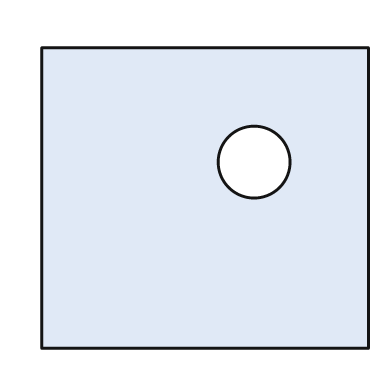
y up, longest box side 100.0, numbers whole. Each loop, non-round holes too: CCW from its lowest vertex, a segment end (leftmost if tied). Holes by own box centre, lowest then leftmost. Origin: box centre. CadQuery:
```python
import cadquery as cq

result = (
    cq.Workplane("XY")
    .moveTo(-50.0, -46.0)
    .lineTo(50.0, -46.0)
    .lineTo(50.0, 46.0)
    .lineTo(-50.0, 46.0)
    .close()
    .moveTo(15.0, 11.0)
    .circle(11.0)
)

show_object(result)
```